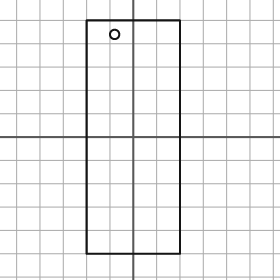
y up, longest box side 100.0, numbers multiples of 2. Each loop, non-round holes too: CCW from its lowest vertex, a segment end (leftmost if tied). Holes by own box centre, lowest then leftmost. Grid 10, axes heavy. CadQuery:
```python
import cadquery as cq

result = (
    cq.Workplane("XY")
    .moveTo(-20.0, -50.0)
    .lineTo(20.0, -50.0)
    .lineTo(20.0, 50.0)
    .lineTo(-20.0, 50.0)
    .close()
    .moveTo(-8.0, 44.0)
    .circle(2.0)
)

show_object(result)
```